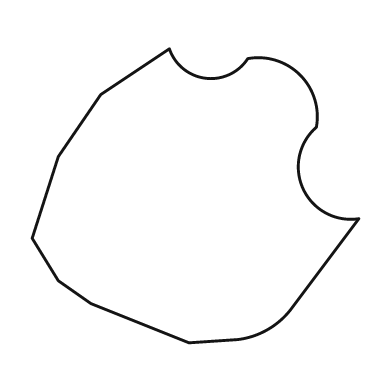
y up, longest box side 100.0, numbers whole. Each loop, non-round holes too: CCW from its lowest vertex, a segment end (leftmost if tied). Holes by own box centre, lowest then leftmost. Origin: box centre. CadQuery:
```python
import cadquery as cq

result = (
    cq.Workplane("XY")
    .moveTo(-2.0, -45.0)
    .lineTo(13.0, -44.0)
    .threePointArc((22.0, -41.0), (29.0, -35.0))
    .lineTo(50.0, -7.0)
    .threePointArc((33.0, 2.0), (37.0, 21.0))
    .threePointArc((32.0, 37.0), (16.0, 42.0))
    .threePointArc((3.0, 36.0), (-8.0, 45.0))
    .lineTo(-29.0, 31.0)
    .lineTo(-42.0, 12.0)
    .lineTo(-50.0, -13.0)
    .lineTo(-42.0, -26.0)
    .lineTo(-32.0, -33.0)
    .close()
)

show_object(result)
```